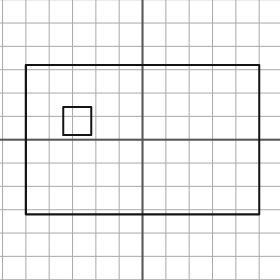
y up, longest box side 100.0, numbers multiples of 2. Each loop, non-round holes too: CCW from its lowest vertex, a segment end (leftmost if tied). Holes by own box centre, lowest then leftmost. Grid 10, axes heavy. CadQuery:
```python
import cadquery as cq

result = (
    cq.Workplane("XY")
    .moveTo(-50.0, -32.0)
    .lineTo(50.0, -32.0)
    .lineTo(50.0, 32.0)
    .lineTo(-50.0, 32.0)
    .close()
    .moveTo(-34.0, 2.0)
    .lineTo(-22.0, 2.0)
    .lineTo(-22.0, 14.0)
    .lineTo(-34.0, 14.0)
    .close()
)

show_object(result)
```